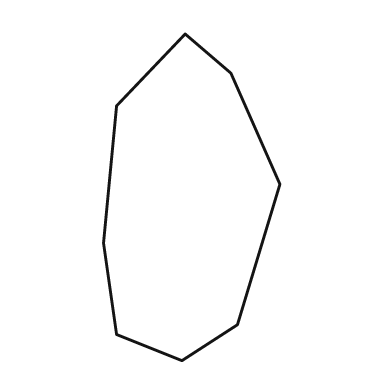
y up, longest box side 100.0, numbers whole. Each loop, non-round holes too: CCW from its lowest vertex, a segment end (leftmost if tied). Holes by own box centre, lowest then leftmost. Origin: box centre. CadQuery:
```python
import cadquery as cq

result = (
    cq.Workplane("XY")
    .moveTo(-3.0, -50.0)
    .lineTo(14.0, -39.0)
    .lineTo(27.0, 4.0)
    .lineTo(12.0, 38.0)
    .lineTo(-2.0, 50.0)
    .lineTo(-23.0, 28.0)
    .lineTo(-27.0, -14.0)
    .lineTo(-23.0, -42.0)
    .close()
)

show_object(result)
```